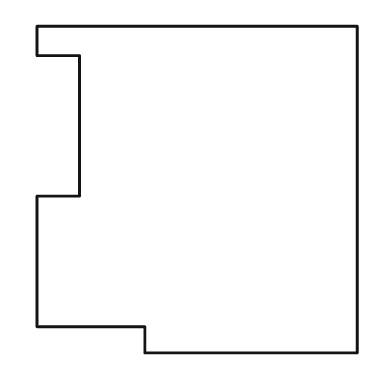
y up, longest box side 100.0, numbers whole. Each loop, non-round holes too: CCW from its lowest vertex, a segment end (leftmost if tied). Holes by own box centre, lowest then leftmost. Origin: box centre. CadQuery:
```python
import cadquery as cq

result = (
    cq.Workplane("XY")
    .moveTo(-16.0, -50.0)
    .lineTo(49.0, -50.0)
    .lineTo(49.0, 50.0)
    .lineTo(-49.0, 50.0)
    .lineTo(-49.0, 41.0)
    .lineTo(-36.0, 41.0)
    .lineTo(-36.0, -2.0)
    .lineTo(-49.0, -2.0)
    .lineTo(-49.0, -42.0)
    .lineTo(-16.0, -42.0)
    .close()
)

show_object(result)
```